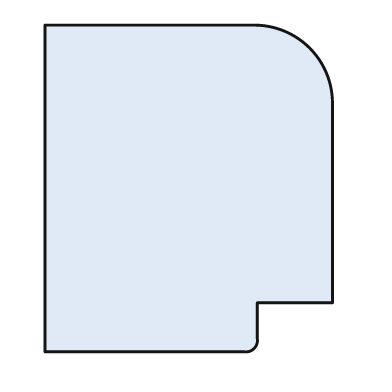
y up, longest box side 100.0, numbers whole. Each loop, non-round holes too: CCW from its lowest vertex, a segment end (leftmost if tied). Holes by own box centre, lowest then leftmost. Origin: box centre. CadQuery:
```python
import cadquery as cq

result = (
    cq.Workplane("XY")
    .moveTo(-44.0, -50.0)
    .lineTo(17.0, -50.0)
    .threePointArc((20.0, -49.0), (21.0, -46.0))
    .lineTo(21.0, -35.0)
    .lineTo(44.0, -35.0)
    .lineTo(44.0, 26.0)
    .threePointArc((37.0, 43.0), (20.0, 50.0))
    .lineTo(-44.0, 50.0)
    .close()
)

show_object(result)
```